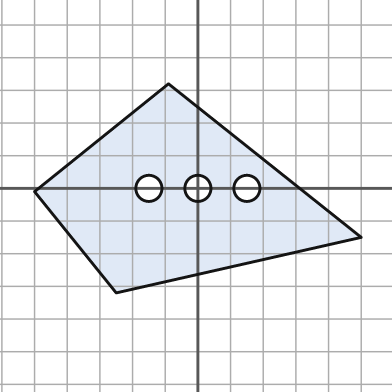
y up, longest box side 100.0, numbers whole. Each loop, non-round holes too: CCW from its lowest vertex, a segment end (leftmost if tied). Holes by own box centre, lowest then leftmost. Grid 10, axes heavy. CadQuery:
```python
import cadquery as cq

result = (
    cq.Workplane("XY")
    .moveTo(-25.0, -32.0)
    .lineTo(50.0, -15.0)
    .lineTo(-9.0, 32.0)
    .lineTo(-50.0, -1.0)
    .close()
    .moveTo(-15.0, 0.0)
    .circle(4.0)
    .moveTo(0.0, 0.0)
    .circle(4.0)
    .moveTo(15.0, 0.0)
    .circle(4.0)
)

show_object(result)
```